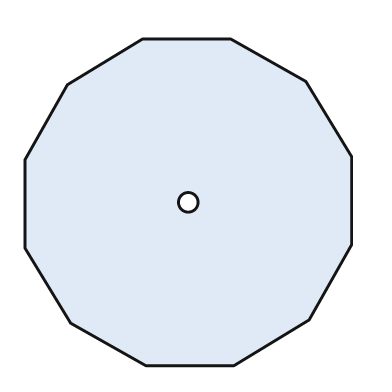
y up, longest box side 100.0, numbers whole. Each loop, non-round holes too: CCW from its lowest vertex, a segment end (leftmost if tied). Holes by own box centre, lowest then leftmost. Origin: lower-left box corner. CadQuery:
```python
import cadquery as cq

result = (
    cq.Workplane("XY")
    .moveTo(37.0, 0.0)
    .lineTo(64.0, 0.0)
    .lineTo(87.0, 14.0)
    .lineTo(100.0, 37.0)
    .lineTo(100.0, 64.0)
    .lineTo(86.0, 87.0)
    .lineTo(63.0, 100.0)
    .lineTo(36.0, 100.0)
    .lineTo(13.0, 86.0)
    .lineTo(0.0, 63.0)
    .lineTo(0.0, 36.0)
    .lineTo(14.0, 13.0)
    .close()
    .moveTo(50.0, 50.0)
    .circle(3.0)
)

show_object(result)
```